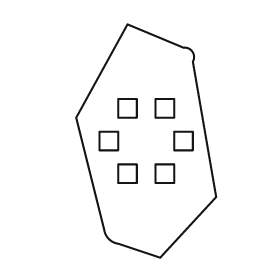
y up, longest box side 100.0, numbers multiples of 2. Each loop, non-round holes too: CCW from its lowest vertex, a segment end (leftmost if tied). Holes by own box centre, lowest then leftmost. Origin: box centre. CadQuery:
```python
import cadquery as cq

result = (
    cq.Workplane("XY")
    .moveTo(6.0, -50.0)
    .lineTo(30.0, -24.0)
    .lineTo(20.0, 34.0)
    .threePointArc((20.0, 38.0), (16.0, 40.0))
    .lineTo(-8.0, 50.0)
    .lineTo(-30.0, 10.0)
    .lineTo(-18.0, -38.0)
    .threePointArc((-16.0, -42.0), (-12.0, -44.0))
    .close()
    .moveTo(-12.0, -18.0)
    .lineTo(-4.0, -18.0)
    .lineTo(-4.0, -10.0)
    .lineTo(-12.0, -10.0)
    .close()
    .moveTo(4.0, -18.0)
    .lineTo(12.0, -18.0)
    .lineTo(12.0, -10.0)
    .lineTo(4.0, -10.0)
    .close()
    .moveTo(-20.0, -4.0)
    .lineTo(-12.0, -4.0)
    .lineTo(-12.0, 4.0)
    .lineTo(-20.0, 4.0)
    .close()
    .moveTo(12.0, -4.0)
    .lineTo(20.0, -4.0)
    .lineTo(20.0, 4.0)
    .lineTo(12.0, 4.0)
    .close()
    .moveTo(-12.0, 10.0)
    .lineTo(-4.0, 10.0)
    .lineTo(-4.0, 18.0)
    .lineTo(-12.0, 18.0)
    .close()
    .moveTo(4.0, 10.0)
    .lineTo(12.0, 10.0)
    .lineTo(12.0, 18.0)
    .lineTo(4.0, 18.0)
    .close()
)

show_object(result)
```